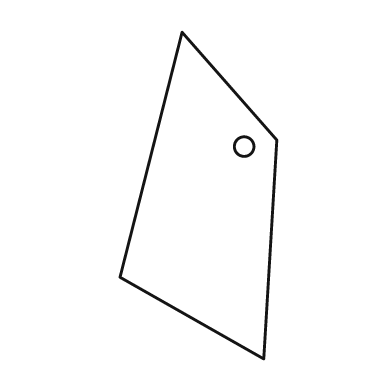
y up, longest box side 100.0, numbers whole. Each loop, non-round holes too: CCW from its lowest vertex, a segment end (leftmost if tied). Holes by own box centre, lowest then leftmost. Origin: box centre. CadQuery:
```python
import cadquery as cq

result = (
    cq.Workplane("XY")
    .moveTo(20.0, -50.0)
    .lineTo(24.0, 17.0)
    .lineTo(-5.0, 50.0)
    .lineTo(-24.0, -25.0)
    .close()
    .moveTo(14.0, 15.0)
    .circle(3.0)
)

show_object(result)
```